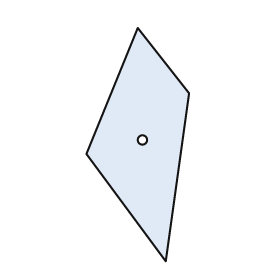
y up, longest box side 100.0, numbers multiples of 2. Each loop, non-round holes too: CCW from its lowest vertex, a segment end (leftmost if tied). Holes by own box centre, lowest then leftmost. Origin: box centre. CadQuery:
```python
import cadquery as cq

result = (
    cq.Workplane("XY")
    .moveTo(12.0, -50.0)
    .lineTo(22.0, 22.0)
    .lineTo(0.0, 50.0)
    .lineTo(-22.0, -4.0)
    .close()
    .moveTo(2.0, 2.0)
    .circle(2.0)
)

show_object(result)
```